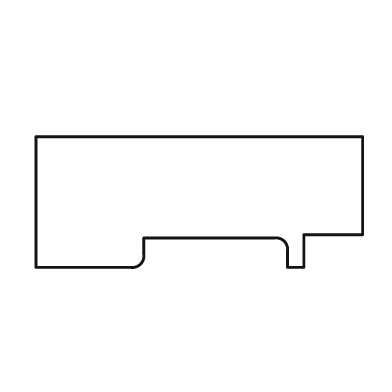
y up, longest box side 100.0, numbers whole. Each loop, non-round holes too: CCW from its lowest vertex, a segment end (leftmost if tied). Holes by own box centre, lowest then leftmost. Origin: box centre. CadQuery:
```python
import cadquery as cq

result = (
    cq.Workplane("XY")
    .moveTo(-50.0, -20.0)
    .lineTo(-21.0, -20.0)
    .threePointArc((-18.0, -19.0), (-17.0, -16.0))
    .lineTo(-17.0, -11.0)
    .lineTo(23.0, -11.0)
    .threePointArc((26.0, -12.0), (27.0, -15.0))
    .lineTo(27.0, -20.0)
    .lineTo(32.0, -20.0)
    .lineTo(32.0, -10.0)
    .lineTo(50.0, -10.0)
    .lineTo(50.0, 20.0)
    .lineTo(-50.0, 20.0)
    .close()
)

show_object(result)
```